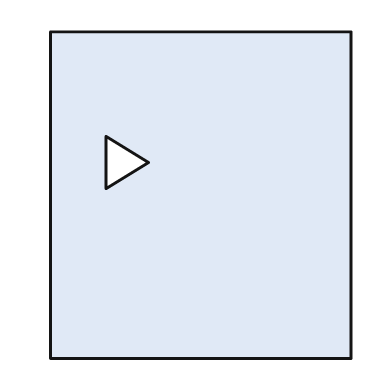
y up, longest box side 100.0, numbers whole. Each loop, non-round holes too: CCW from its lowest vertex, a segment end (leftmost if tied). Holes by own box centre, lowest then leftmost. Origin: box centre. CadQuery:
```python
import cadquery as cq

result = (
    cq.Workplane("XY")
    .moveTo(-46.0, -50.0)
    .lineTo(46.0, -50.0)
    .lineTo(46.0, 50.0)
    .lineTo(-46.0, 50.0)
    .close()
    .moveTo(-29.0, 2.0)
    .lineTo(-16.0, 10.0)
    .lineTo(-29.0, 18.0)
    .close()
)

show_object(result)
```